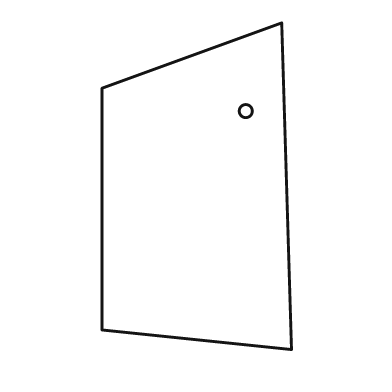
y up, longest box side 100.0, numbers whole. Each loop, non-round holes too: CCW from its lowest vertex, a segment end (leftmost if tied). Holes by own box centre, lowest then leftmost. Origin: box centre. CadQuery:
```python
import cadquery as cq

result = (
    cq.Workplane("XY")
    .moveTo(29.0, -50.0)
    .lineTo(26.0, 50.0)
    .lineTo(-29.0, 30.0)
    .lineTo(-29.0, -44.0)
    .close()
    .moveTo(15.0, 23.0)
    .circle(2.0)
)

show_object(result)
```